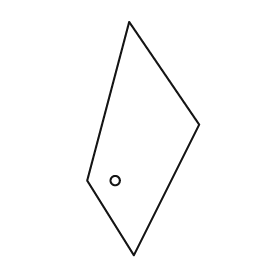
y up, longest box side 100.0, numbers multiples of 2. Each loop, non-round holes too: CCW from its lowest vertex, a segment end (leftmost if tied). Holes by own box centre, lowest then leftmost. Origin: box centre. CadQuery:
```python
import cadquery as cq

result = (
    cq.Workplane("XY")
    .moveTo(-4.0, -50.0)
    .lineTo(24.0, 6.0)
    .lineTo(-6.0, 50.0)
    .lineTo(-24.0, -18.0)
    .close()
    .moveTo(-12.0, -18.0)
    .circle(2.0)
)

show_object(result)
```